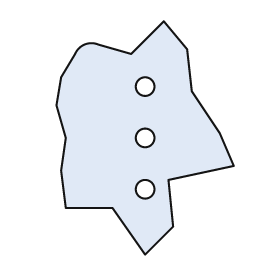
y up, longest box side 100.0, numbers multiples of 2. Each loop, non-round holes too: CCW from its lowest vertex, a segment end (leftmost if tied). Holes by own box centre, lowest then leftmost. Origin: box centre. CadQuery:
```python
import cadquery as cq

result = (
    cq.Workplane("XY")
    .moveTo(0.0, -50.0)
    .lineTo(12.0, -38.0)
    .lineTo(10.0, -18.0)
    .lineTo(38.0, -12.0)
    .lineTo(32.0, 2.0)
    .lineTo(20.0, 20.0)
    .lineTo(18.0, 38.0)
    .lineTo(8.0, 50.0)
    .lineTo(-6.0, 36.0)
    .lineTo(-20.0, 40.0)
    .threePointArc((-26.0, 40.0), (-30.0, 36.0))
    .lineTo(-36.0, 26.0)
    .lineTo(-38.0, 14.0)
    .lineTo(-34.0, 0.0)
    .lineTo(-36.0, -14.0)
    .lineTo(-34.0, -30.0)
    .lineTo(-14.0, -30.0)
    .close()
    .moveTo(0.0, -22.0)
    .circle(4.0)
    .moveTo(0.0, 0.0)
    .circle(4.0)
    .moveTo(0.0, 22.0)
    .circle(4.0)
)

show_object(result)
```